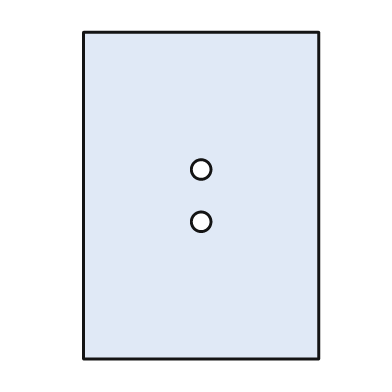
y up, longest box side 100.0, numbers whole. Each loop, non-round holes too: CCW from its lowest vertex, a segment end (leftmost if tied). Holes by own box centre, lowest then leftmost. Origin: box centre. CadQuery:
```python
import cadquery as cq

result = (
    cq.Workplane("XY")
    .moveTo(-36.0, -50.0)
    .lineTo(36.0, -50.0)
    .lineTo(36.0, 50.0)
    .lineTo(-36.0, 50.0)
    .close()
    .moveTo(0.0, -8.0)
    .circle(3.0)
    .moveTo(0.0, 8.0)
    .circle(3.0)
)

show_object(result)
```